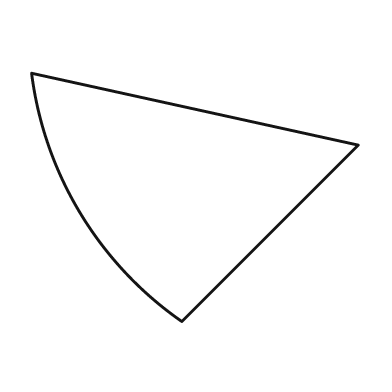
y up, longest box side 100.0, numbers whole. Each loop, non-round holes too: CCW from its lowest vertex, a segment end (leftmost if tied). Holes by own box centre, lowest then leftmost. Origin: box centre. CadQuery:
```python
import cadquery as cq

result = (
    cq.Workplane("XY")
    .moveTo(-4.0, -38.0)
    .lineTo(50.0, 16.0)
    .lineTo(-50.0, 38.0)
    .threePointArc((-35.0, -5.0), (-4.0, -38.0))
    .close()
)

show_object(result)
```